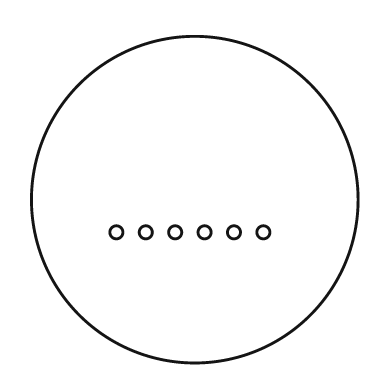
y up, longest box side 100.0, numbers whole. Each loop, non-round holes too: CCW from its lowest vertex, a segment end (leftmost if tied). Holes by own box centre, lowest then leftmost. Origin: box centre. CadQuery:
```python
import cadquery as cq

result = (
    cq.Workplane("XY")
    .moveTo(0.0, 0.0)
    .circle(50.0)
    .moveTo(-24.0, -10.0)
    .circle(2.0)
    .moveTo(-15.0, -10.0)
    .circle(2.0)
    .moveTo(-6.0, -10.0)
    .circle(2.0)
    .moveTo(3.0, -10.0)
    .circle(2.0)
    .moveTo(12.0, -10.0)
    .circle(2.0)
    .moveTo(21.0, -10.0)
    .circle(2.0)
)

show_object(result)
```